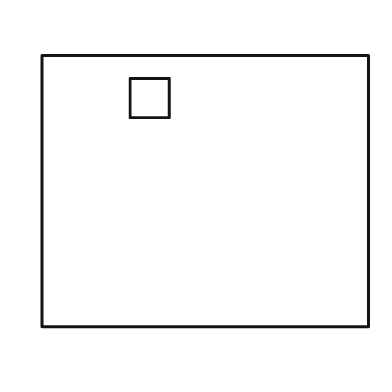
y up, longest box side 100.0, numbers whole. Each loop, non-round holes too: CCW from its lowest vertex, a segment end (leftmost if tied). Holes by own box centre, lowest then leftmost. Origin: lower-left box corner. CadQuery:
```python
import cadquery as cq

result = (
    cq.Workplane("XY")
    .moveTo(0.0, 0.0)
    .lineTo(100.0, 0.0)
    .lineTo(100.0, 83.0)
    .lineTo(0.0, 83.0)
    .close()
    .moveTo(27.0, 64.0)
    .lineTo(39.0, 64.0)
    .lineTo(39.0, 76.0)
    .lineTo(27.0, 76.0)
    .close()
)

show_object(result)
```